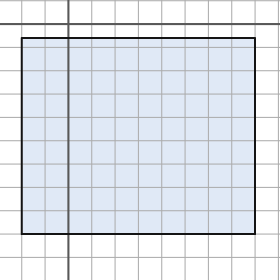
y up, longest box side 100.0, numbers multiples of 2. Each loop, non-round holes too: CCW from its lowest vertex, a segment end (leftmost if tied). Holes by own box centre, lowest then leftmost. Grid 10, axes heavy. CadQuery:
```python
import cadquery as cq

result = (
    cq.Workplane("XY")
    .moveTo(-20.0, -90.0)
    .lineTo(80.0, -90.0)
    .lineTo(80.0, -6.0)
    .lineTo(-20.0, -6.0)
    .close()
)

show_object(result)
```